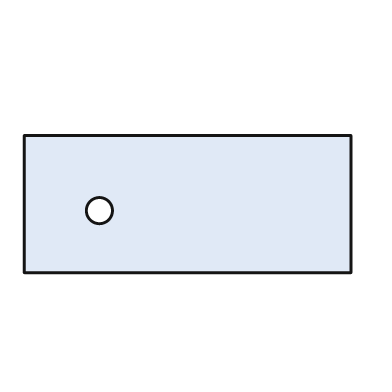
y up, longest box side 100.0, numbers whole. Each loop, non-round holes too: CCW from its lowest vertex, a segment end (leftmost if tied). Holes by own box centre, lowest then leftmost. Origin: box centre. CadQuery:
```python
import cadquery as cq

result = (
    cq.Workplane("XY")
    .moveTo(-50.0, -21.0)
    .lineTo(50.0, -21.0)
    .lineTo(50.0, 21.0)
    .lineTo(-50.0, 21.0)
    .close()
    .moveTo(-27.0, -2.0)
    .circle(4.0)
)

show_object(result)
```